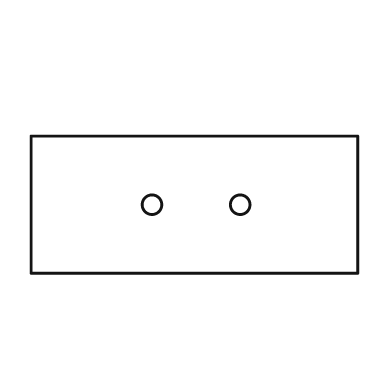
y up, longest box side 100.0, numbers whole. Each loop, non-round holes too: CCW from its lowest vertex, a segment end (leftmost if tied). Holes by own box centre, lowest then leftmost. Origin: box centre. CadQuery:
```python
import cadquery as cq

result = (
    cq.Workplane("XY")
    .moveTo(-50.0, -21.0)
    .lineTo(50.0, -21.0)
    .lineTo(50.0, 21.0)
    .lineTo(-50.0, 21.0)
    .close()
    .moveTo(-13.0, 0.0)
    .circle(3.0)
    .moveTo(14.0, 0.0)
    .circle(3.0)
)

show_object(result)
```